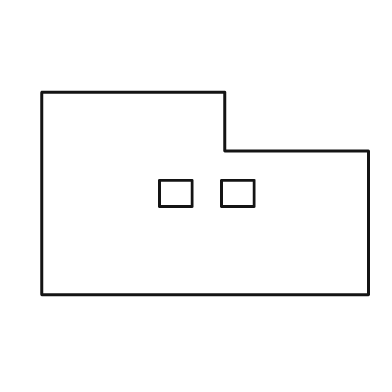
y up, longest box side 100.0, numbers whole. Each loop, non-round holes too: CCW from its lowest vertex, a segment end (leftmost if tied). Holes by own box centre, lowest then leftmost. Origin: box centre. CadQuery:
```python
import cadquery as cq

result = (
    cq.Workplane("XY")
    .moveTo(-50.0, -31.0)
    .lineTo(50.0, -31.0)
    .lineTo(50.0, 13.0)
    .lineTo(6.0, 13.0)
    .lineTo(6.0, 31.0)
    .lineTo(-50.0, 31.0)
    .close()
    .moveTo(-14.0, -4.0)
    .lineTo(-4.0, -4.0)
    .lineTo(-4.0, 4.0)
    .lineTo(-14.0, 4.0)
    .close()
    .moveTo(5.0, -4.0)
    .lineTo(15.0, -4.0)
    .lineTo(15.0, 4.0)
    .lineTo(5.0, 4.0)
    .close()
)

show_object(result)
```